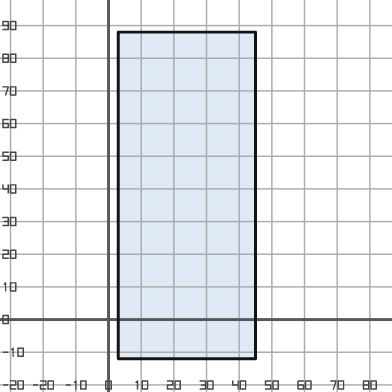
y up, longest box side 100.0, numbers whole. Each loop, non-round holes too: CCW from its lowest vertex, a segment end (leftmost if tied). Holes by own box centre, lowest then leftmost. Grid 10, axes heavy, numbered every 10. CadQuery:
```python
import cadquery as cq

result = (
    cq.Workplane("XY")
    .moveTo(3.0, -12.0)
    .lineTo(45.0, -12.0)
    .lineTo(45.0, 88.0)
    .lineTo(3.0, 88.0)
    .close()
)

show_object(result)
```